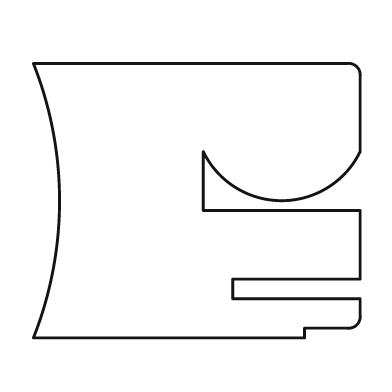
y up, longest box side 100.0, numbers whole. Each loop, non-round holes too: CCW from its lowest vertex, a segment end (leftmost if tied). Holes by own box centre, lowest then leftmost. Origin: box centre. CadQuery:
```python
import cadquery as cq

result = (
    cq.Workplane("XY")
    .moveTo(-50.0, -42.0)
    .lineTo(33.0, -42.0)
    .lineTo(33.0, -39.0)
    .lineTo(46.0, -39.0)
    .threePointArc((49.0, -38.0), (50.0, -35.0))
    .lineTo(50.0, -30.0)
    .lineTo(11.0, -30.0)
    .lineTo(11.0, -24.0)
    .lineTo(50.0, -24.0)
    .lineTo(50.0, -3.0)
    .lineTo(2.0, -3.0)
    .lineTo(2.0, 15.0)
    .threePointArc((26.0, 0.0), (50.0, 15.0))
    .lineTo(50.0, 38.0)
    .threePointArc((49.0, 41.0), (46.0, 42.0))
    .lineTo(-50.0, 42.0)
    .threePointArc((-42.0, 0.0), (-50.0, -42.0))
    .close()
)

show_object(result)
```